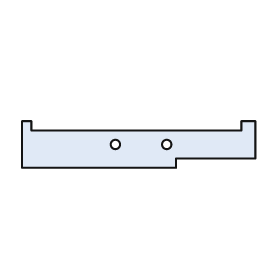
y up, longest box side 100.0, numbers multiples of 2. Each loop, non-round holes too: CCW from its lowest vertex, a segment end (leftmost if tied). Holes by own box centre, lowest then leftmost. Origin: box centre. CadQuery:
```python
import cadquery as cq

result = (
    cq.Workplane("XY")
    .moveTo(-50.0, -10.0)
    .lineTo(16.0, -10.0)
    .lineTo(16.0, -6.0)
    .lineTo(50.0, -6.0)
    .lineTo(50.0, 10.0)
    .lineTo(44.0, 10.0)
    .lineTo(44.0, 6.0)
    .lineTo(-46.0, 6.0)
    .lineTo(-46.0, 10.0)
    .lineTo(-50.0, 10.0)
    .close()
    .moveTo(-10.0, 0.0)
    .circle(2.0)
    .moveTo(12.0, 0.0)
    .circle(2.0)
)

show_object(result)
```